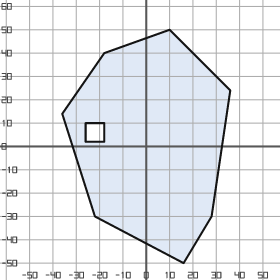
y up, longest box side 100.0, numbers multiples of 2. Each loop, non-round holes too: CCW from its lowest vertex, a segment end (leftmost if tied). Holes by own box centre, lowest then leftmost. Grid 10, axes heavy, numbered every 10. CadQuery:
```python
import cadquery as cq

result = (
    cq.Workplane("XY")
    .moveTo(16.0, -50.0)
    .lineTo(28.0, -30.0)
    .lineTo(36.0, 24.0)
    .lineTo(10.0, 50.0)
    .lineTo(-18.0, 40.0)
    .lineTo(-36.0, 14.0)
    .lineTo(-22.0, -30.0)
    .close()
    .moveTo(-26.0, 2.0)
    .lineTo(-18.0, 2.0)
    .lineTo(-18.0, 10.0)
    .lineTo(-26.0, 10.0)
    .close()
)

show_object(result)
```